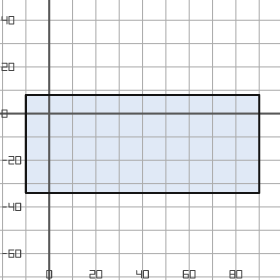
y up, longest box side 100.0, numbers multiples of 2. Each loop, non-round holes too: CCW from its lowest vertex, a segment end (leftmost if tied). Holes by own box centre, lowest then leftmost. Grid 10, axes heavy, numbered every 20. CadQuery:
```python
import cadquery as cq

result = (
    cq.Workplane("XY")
    .moveTo(-10.0, -34.0)
    .lineTo(90.0, -34.0)
    .lineTo(90.0, 8.0)
    .lineTo(-10.0, 8.0)
    .close()
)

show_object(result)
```